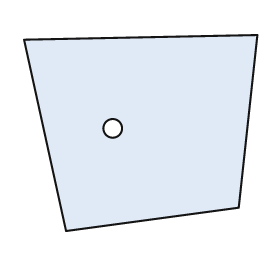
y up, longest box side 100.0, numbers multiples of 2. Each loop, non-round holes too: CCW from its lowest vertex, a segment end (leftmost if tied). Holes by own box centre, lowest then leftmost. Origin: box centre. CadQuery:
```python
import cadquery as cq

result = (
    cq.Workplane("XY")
    .moveTo(-32.0, -42.0)
    .lineTo(42.0, -32.0)
    .lineTo(50.0, 42.0)
    .lineTo(-50.0, 40.0)
    .close()
    .moveTo(-12.0, 2.0)
    .circle(4.0)
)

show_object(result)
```